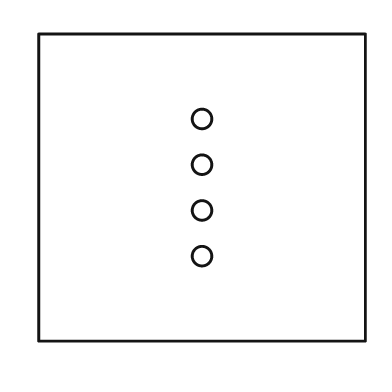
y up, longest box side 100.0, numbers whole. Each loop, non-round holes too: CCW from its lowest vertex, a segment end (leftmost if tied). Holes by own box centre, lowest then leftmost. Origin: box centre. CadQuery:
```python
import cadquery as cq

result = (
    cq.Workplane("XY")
    .moveTo(-50.0, -47.0)
    .lineTo(50.0, -47.0)
    .lineTo(50.0, 47.0)
    .lineTo(-50.0, 47.0)
    .close()
    .moveTo(0.0, -21.0)
    .circle(3.0)
    .moveTo(0.0, -7.0)
    .circle(3.0)
    .moveTo(0.0, 7.0)
    .circle(3.0)
    .moveTo(0.0, 21.0)
    .circle(3.0)
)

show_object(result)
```